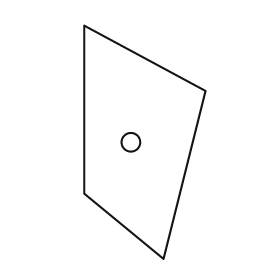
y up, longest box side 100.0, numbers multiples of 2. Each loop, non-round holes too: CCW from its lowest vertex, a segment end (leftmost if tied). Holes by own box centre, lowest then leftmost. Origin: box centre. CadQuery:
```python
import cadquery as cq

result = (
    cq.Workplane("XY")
    .moveTo(8.0, -50.0)
    .lineTo(26.0, 22.0)
    .lineTo(-26.0, 50.0)
    .lineTo(-26.0, -22.0)
    .close()
    .moveTo(-6.0, 0.0)
    .circle(4.0)
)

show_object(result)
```